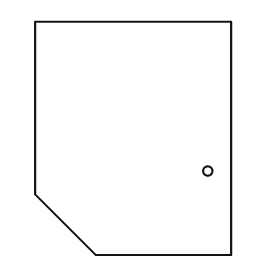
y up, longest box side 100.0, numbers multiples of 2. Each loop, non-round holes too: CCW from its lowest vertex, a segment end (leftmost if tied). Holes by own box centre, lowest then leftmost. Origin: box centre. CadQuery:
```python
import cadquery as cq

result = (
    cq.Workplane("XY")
    .moveTo(-16.0, -50.0)
    .lineTo(42.0, -50.0)
    .lineTo(42.0, 50.0)
    .lineTo(-42.0, 50.0)
    .lineTo(-42.0, -24.0)
    .close()
    .moveTo(32.0, -14.0)
    .circle(2.0)
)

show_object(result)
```